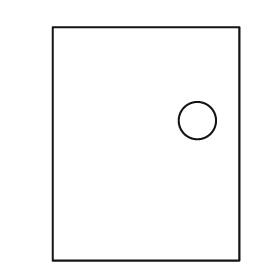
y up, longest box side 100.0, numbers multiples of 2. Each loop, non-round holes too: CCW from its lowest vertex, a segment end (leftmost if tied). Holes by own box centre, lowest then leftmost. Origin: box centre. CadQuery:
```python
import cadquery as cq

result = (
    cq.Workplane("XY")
    .moveTo(-40.0, -50.0)
    .lineTo(40.0, -50.0)
    .lineTo(40.0, 50.0)
    .lineTo(-40.0, 50.0)
    .close()
    .moveTo(22.0, 10.0)
    .circle(8.0)
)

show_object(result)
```